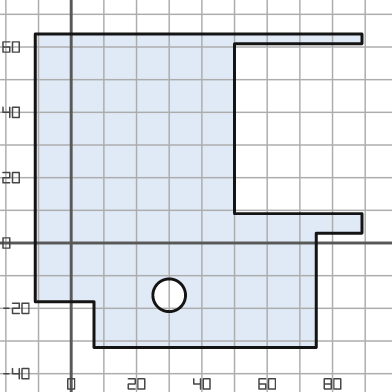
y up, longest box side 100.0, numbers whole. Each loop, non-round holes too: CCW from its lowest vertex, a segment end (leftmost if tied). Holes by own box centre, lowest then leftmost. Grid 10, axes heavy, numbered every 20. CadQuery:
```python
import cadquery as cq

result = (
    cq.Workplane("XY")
    .moveTo(7.0, -32.0)
    .lineTo(75.0, -32.0)
    .lineTo(75.0, 3.0)
    .lineTo(89.0, 3.0)
    .lineTo(89.0, 9.0)
    .lineTo(50.0, 9.0)
    .lineTo(50.0, 61.0)
    .lineTo(89.0, 61.0)
    .lineTo(89.0, 64.0)
    .lineTo(-11.0, 64.0)
    .lineTo(-11.0, -18.0)
    .lineTo(7.0, -18.0)
    .close()
    .moveTo(30.0, -16.0)
    .circle(5.0)
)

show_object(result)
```